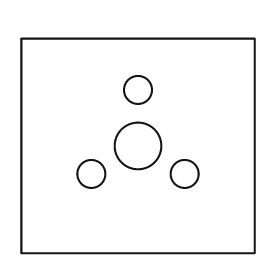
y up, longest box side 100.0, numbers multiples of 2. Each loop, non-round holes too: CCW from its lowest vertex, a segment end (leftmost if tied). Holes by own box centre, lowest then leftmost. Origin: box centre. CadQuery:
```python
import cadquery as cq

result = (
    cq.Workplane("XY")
    .moveTo(-50.0, -46.0)
    .lineTo(50.0, -46.0)
    .lineTo(50.0, 46.0)
    .lineTo(-50.0, 46.0)
    .close()
    .moveTo(-20.0, -12.0)
    .circle(6.0)
    .moveTo(20.0, -12.0)
    .circle(6.0)
    .moveTo(0.0, 0.0)
    .circle(10.0)
    .moveTo(0.0, 24.0)
    .circle(6.0)
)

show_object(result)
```